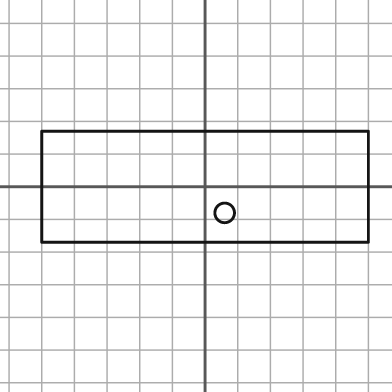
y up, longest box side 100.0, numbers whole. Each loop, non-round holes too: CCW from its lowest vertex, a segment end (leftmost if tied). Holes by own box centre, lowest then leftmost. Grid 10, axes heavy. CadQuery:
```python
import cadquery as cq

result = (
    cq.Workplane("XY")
    .moveTo(-50.0, -17.0)
    .lineTo(50.0, -17.0)
    .lineTo(50.0, 17.0)
    .lineTo(-50.0, 17.0)
    .close()
    .moveTo(6.0, -8.0)
    .circle(3.0)
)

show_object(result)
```